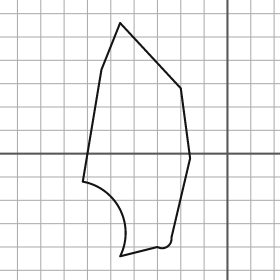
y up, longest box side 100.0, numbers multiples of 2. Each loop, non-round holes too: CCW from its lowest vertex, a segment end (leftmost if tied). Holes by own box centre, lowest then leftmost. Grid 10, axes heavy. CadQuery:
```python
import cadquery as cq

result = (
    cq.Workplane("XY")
    .moveTo(-46.0, -44.0)
    .lineTo(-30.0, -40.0)
    .threePointArc((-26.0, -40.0), (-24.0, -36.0))
    .lineTo(-16.0, -2.0)
    .lineTo(-20.0, 28.0)
    .lineTo(-46.0, 56.0)
    .lineTo(-54.0, 36.0)
    .lineTo(-62.0, -12.0)
    .threePointArc((-46.0, -24.0), (-46.0, -44.0))
    .close()
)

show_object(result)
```